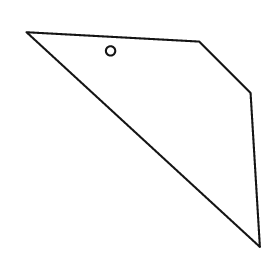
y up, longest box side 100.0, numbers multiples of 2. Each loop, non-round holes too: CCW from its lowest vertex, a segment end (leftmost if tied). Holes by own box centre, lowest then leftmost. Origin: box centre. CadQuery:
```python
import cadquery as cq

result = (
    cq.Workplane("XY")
    .moveTo(50.0, -46.0)
    .lineTo(46.0, 20.0)
    .lineTo(24.0, 42.0)
    .lineTo(-50.0, 46.0)
    .close()
    .moveTo(-14.0, 38.0)
    .circle(2.0)
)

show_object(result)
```